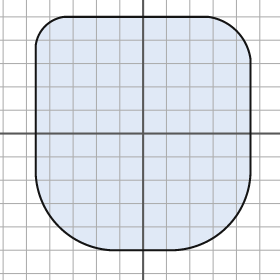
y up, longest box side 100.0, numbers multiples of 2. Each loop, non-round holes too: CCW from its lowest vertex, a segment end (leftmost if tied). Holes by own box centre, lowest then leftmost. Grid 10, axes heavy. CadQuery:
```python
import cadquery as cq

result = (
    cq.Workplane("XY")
    .moveTo(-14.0, -50.0)
    .lineTo(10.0, -50.0)
    .threePointArc((36.0, -40.0), (46.0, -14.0))
    .lineTo(46.0, 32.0)
    .threePointArc((40.0, 44.0), (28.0, 50.0))
    .lineTo(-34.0, 50.0)
    .threePointArc((-42.0, 46.0), (-46.0, 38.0))
    .lineTo(-46.0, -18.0)
    .threePointArc((-36.0, -40.0), (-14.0, -50.0))
    .close()
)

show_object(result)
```